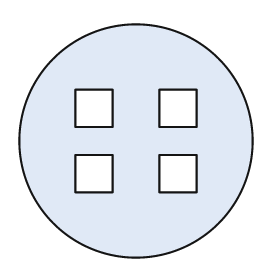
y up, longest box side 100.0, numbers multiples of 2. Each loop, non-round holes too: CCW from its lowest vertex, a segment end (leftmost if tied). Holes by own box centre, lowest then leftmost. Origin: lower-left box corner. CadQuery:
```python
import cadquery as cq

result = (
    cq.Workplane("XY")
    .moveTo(50.0, 50.0)
    .circle(50.0)
    .moveTo(24.0, 28.0)
    .lineTo(40.0, 28.0)
    .lineTo(40.0, 44.0)
    .lineTo(24.0, 44.0)
    .close()
    .moveTo(60.0, 28.0)
    .lineTo(76.0, 28.0)
    .lineTo(76.0, 44.0)
    .lineTo(60.0, 44.0)
    .close()
    .moveTo(24.0, 56.0)
    .lineTo(40.0, 56.0)
    .lineTo(40.0, 72.0)
    .lineTo(24.0, 72.0)
    .close()
    .moveTo(60.0, 56.0)
    .lineTo(76.0, 56.0)
    .lineTo(76.0, 72.0)
    .lineTo(60.0, 72.0)
    .close()
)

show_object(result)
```